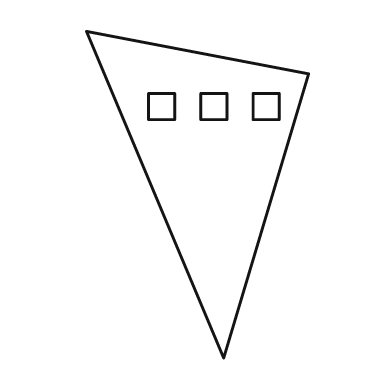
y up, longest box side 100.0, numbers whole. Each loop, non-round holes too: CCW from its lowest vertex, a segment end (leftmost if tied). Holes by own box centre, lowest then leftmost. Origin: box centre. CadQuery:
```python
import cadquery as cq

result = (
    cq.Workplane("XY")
    .moveTo(8.0, -50.0)
    .lineTo(34.0, 37.0)
    .lineTo(-34.0, 50.0)
    .close()
    .moveTo(-15.0, 23.0)
    .lineTo(-7.0, 23.0)
    .lineTo(-7.0, 31.0)
    .lineTo(-15.0, 31.0)
    .close()
    .moveTo(1.0, 23.0)
    .lineTo(9.0, 23.0)
    .lineTo(9.0, 31.0)
    .lineTo(1.0, 31.0)
    .close()
    .moveTo(17.0, 23.0)
    .lineTo(25.0, 23.0)
    .lineTo(25.0, 31.0)
    .lineTo(17.0, 31.0)
    .close()
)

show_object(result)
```